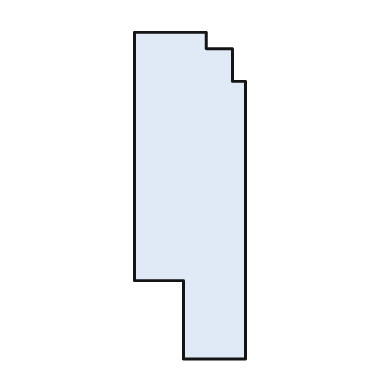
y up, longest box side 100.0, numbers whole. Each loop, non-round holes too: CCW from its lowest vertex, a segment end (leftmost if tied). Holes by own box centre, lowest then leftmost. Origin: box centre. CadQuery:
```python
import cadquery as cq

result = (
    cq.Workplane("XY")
    .moveTo(-2.0, -50.0)
    .lineTo(17.0, -50.0)
    .lineTo(17.0, 35.0)
    .lineTo(13.0, 35.0)
    .lineTo(13.0, 45.0)
    .lineTo(5.0, 45.0)
    .lineTo(5.0, 50.0)
    .lineTo(-17.0, 50.0)
    .lineTo(-17.0, -26.0)
    .lineTo(-2.0, -26.0)
    .close()
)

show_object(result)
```